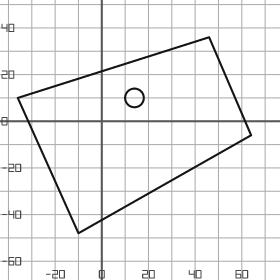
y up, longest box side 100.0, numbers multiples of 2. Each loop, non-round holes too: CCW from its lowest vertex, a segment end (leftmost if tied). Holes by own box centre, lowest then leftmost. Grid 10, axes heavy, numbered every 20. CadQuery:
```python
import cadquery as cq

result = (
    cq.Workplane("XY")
    .moveTo(-10.0, -48.0)
    .lineTo(64.0, -6.0)
    .lineTo(46.0, 36.0)
    .lineTo(-36.0, 10.0)
    .close()
    .moveTo(14.0, 10.0)
    .circle(4.0)
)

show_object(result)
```